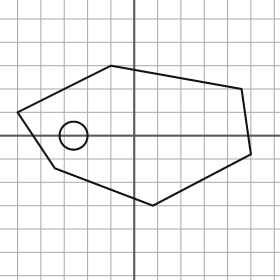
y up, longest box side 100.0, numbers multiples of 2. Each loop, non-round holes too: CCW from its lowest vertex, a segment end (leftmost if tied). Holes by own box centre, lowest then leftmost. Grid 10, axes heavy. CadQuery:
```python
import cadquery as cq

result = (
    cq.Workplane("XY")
    .moveTo(8.0, -30.0)
    .lineTo(50.0, -8.0)
    .lineTo(46.0, 20.0)
    .lineTo(-10.0, 30.0)
    .lineTo(-50.0, 10.0)
    .lineTo(-34.0, -14.0)
    .close()
    .moveTo(-26.0, 0.0)
    .circle(6.0)
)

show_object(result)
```